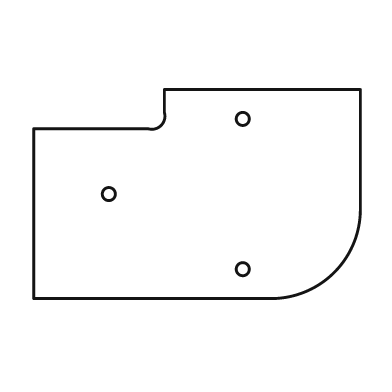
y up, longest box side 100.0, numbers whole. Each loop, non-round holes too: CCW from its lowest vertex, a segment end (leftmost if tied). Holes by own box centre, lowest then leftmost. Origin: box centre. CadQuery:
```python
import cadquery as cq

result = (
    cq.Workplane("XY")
    .moveTo(-50.0, -32.0)
    .lineTo(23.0, -32.0)
    .threePointArc((42.0, -24.0), (50.0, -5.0))
    .lineTo(50.0, 32.0)
    .lineTo(-10.0, 32.0)
    .lineTo(-10.0, 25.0)
    .threePointArc((-11.0, 21.0), (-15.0, 20.0))
    .lineTo(-50.0, 20.0)
    .close()
    .moveTo(14.0, -23.0)
    .circle(2.0)
    .moveTo(-27.0, 0.0)
    .circle(2.0)
    .moveTo(14.0, 23.0)
    .circle(2.0)
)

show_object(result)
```